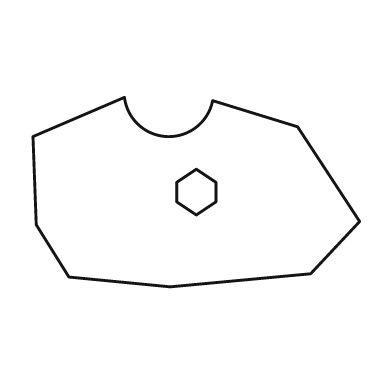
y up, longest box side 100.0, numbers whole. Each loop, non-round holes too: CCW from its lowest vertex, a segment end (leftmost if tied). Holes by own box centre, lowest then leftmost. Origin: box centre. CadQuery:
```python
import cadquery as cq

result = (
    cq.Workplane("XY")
    .moveTo(-8.0, -29.0)
    .lineTo(35.0, -25.0)
    .lineTo(50.0, -9.0)
    .lineTo(31.0, 20.0)
    .lineTo(5.0, 28.0)
    .threePointArc((-9.0, 17.0), (-22.0, 29.0))
    .lineTo(-50.0, 17.0)
    .lineTo(-49.0, -10.0)
    .lineTo(-39.0, -26.0)
    .close()
    .moveTo(0.0, -7.0)
    .lineTo(6.0, -3.0)
    .lineTo(6.0, 3.0)
    .lineTo(0.0, 7.0)
    .lineTo(-6.0, 3.0)
    .lineTo(-6.0, -3.0)
    .close()
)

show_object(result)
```